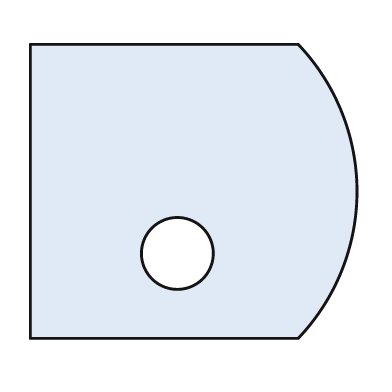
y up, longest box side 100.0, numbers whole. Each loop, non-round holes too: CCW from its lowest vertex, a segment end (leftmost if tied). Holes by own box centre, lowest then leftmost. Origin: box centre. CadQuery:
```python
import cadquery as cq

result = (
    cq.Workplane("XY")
    .moveTo(-50.0, -45.0)
    .lineTo(32.0, -45.0)
    .threePointArc((50.0, 0.0), (32.0, 45.0))
    .lineTo(-50.0, 45.0)
    .close()
    .moveTo(-5.0, -19.0)
    .circle(11.0)
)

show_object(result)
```